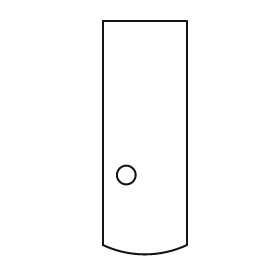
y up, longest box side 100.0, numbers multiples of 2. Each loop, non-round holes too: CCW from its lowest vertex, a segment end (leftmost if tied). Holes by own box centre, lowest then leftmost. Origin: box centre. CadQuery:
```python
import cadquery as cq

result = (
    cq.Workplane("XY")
    .moveTo(-18.0, -46.0)
    .threePointArc((0.0, -50.0), (18.0, -46.0))
    .lineTo(18.0, 50.0)
    .lineTo(-18.0, 50.0)
    .close()
    .moveTo(-8.0, -16.0)
    .circle(4.0)
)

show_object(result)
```